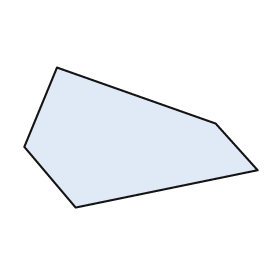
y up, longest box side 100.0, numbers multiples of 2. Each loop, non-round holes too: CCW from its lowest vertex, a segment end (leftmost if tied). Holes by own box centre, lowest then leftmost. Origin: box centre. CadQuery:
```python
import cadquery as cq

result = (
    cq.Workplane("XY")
    .moveTo(-28.0, -30.0)
    .lineTo(50.0, -14.0)
    .lineTo(32.0, 6.0)
    .lineTo(-36.0, 30.0)
    .lineTo(-50.0, -4.0)
    .close()
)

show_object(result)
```